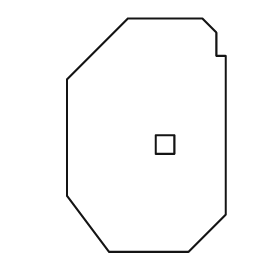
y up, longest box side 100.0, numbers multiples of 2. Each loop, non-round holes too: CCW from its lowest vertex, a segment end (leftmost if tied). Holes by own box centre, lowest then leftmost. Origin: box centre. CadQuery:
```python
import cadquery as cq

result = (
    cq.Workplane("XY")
    .moveTo(-16.0, -50.0)
    .lineTo(18.0, -50.0)
    .lineTo(34.0, -34.0)
    .lineTo(34.0, 34.0)
    .lineTo(30.0, 34.0)
    .lineTo(30.0, 44.0)
    .lineTo(24.0, 50.0)
    .lineTo(-8.0, 50.0)
    .lineTo(-34.0, 24.0)
    .lineTo(-34.0, -26.0)
    .close()
    .moveTo(4.0, -8.0)
    .lineTo(12.0, -8.0)
    .lineTo(12.0, 0.0)
    .lineTo(4.0, 0.0)
    .close()
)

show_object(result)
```